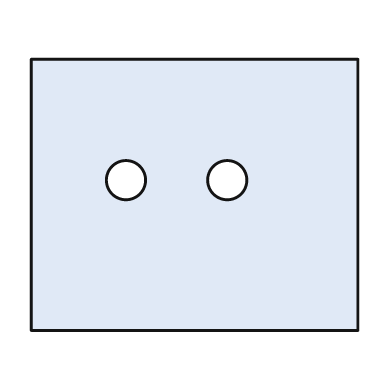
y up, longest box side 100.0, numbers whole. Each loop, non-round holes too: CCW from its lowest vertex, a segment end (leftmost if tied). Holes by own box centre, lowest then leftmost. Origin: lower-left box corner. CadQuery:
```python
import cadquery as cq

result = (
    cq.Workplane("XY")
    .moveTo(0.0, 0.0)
    .lineTo(100.0, 0.0)
    .lineTo(100.0, 83.0)
    .lineTo(0.0, 83.0)
    .close()
    .moveTo(29.0, 46.0)
    .circle(6.0)
    .moveTo(60.0, 46.0)
    .circle(6.0)
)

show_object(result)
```